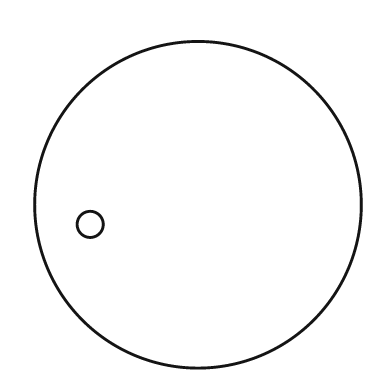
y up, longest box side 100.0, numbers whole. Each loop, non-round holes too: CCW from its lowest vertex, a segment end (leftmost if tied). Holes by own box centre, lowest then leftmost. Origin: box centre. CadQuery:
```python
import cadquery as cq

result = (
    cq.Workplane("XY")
    .moveTo(0.0, 0.0)
    .circle(50.0)
    .moveTo(-33.0, -6.0)
    .circle(4.0)
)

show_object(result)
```